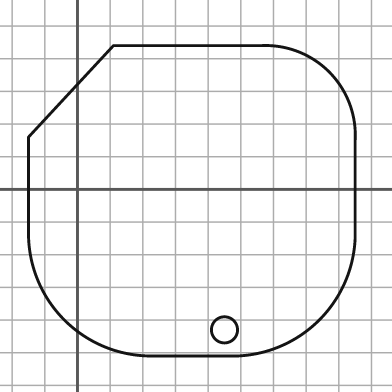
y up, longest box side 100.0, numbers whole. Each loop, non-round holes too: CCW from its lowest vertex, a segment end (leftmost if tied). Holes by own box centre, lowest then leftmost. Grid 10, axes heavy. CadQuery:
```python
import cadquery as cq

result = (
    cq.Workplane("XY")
    .moveTo(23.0, -51.0)
    .lineTo(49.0, -51.0)
    .threePointArc((74.0, -40.0), (85.0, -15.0))
    .lineTo(85.0, 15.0)
    .threePointArc((77.0, 36.0), (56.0, 44.0))
    .lineTo(11.0, 44.0)
    .lineTo(-15.0, 16.0)
    .lineTo(-15.0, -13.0)
    .threePointArc((-4.0, -40.0), (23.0, -51.0))
    .close()
    .moveTo(45.0, -43.0)
    .circle(4.0)
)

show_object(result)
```